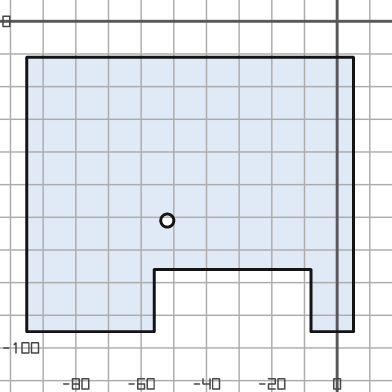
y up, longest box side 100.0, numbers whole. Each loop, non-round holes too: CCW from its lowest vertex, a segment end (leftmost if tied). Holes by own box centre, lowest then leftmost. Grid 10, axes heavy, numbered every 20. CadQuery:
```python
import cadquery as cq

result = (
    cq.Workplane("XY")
    .moveTo(-95.0, -95.0)
    .lineTo(-56.0, -95.0)
    .lineTo(-56.0, -76.0)
    .lineTo(-8.0, -76.0)
    .lineTo(-8.0, -95.0)
    .lineTo(5.0, -95.0)
    .lineTo(5.0, -11.0)
    .lineTo(-95.0, -11.0)
    .close()
    .moveTo(-52.0, -61.0)
    .circle(2.0)
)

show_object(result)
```